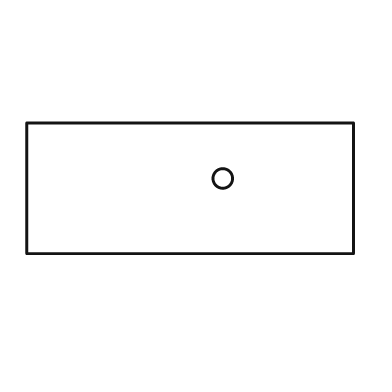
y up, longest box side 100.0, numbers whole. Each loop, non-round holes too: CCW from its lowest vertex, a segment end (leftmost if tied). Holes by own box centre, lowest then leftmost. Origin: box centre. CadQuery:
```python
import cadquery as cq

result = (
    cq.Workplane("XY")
    .moveTo(-50.0, -20.0)
    .lineTo(50.0, -20.0)
    .lineTo(50.0, 20.0)
    .lineTo(-50.0, 20.0)
    .close()
    .moveTo(10.0, 3.0)
    .circle(3.0)
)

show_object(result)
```